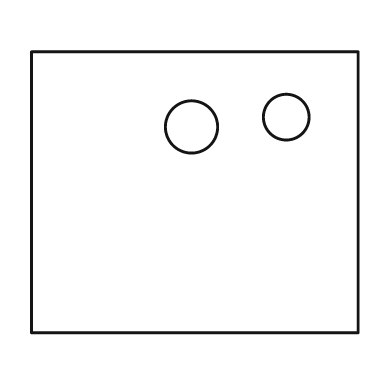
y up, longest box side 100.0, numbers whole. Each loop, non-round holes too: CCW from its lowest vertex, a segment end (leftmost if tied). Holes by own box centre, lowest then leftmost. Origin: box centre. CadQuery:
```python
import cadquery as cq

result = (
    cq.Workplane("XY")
    .moveTo(-50.0, -43.0)
    .lineTo(50.0, -43.0)
    .lineTo(50.0, 43.0)
    .lineTo(-50.0, 43.0)
    .close()
    .moveTo(-1.0, 20.0)
    .circle(8.0)
    .moveTo(28.0, 23.0)
    .circle(7.0)
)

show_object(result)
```